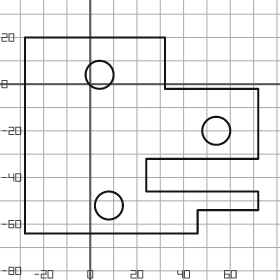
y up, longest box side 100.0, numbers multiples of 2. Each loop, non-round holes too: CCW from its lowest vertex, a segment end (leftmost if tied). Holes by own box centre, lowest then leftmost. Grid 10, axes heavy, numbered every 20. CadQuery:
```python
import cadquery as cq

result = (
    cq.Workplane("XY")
    .moveTo(-28.0, -64.0)
    .lineTo(46.0, -64.0)
    .lineTo(46.0, -54.0)
    .lineTo(72.0, -54.0)
    .lineTo(72.0, -46.0)
    .lineTo(24.0, -46.0)
    .lineTo(24.0, -32.0)
    .lineTo(72.0, -32.0)
    .lineTo(72.0, -2.0)
    .lineTo(32.0, -2.0)
    .lineTo(32.0, 20.0)
    .lineTo(-28.0, 20.0)
    .close()
    .moveTo(8.0, -52.0)
    .circle(6.0)
    .moveTo(54.0, -20.0)
    .circle(6.0)
    .moveTo(4.0, 4.0)
    .circle(6.0)
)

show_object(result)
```